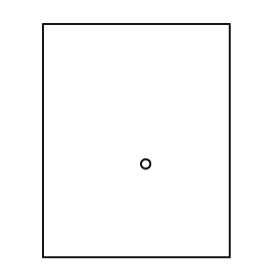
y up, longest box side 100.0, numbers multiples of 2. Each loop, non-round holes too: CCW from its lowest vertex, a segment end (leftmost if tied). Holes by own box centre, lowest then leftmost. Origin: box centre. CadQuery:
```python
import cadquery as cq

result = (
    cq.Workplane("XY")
    .moveTo(-40.0, -50.0)
    .lineTo(40.0, -50.0)
    .lineTo(40.0, 50.0)
    .lineTo(-40.0, 50.0)
    .close()
    .moveTo(4.0, -10.0)
    .circle(2.0)
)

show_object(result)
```